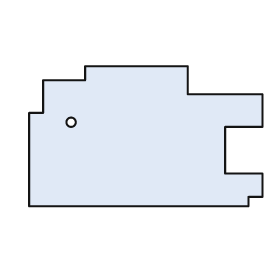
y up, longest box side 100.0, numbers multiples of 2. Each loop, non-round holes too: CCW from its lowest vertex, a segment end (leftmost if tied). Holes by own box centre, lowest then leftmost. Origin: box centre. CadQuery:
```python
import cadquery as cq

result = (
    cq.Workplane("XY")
    .moveTo(-50.0, -30.0)
    .lineTo(44.0, -30.0)
    .lineTo(44.0, -26.0)
    .lineTo(50.0, -26.0)
    .lineTo(50.0, -16.0)
    .lineTo(34.0, -16.0)
    .lineTo(34.0, 4.0)
    .lineTo(50.0, 4.0)
    .lineTo(50.0, 18.0)
    .lineTo(18.0, 18.0)
    .lineTo(18.0, 30.0)
    .lineTo(-26.0, 30.0)
    .lineTo(-26.0, 24.0)
    .lineTo(-44.0, 24.0)
    .lineTo(-44.0, 10.0)
    .lineTo(-50.0, 10.0)
    .close()
    .moveTo(-32.0, 6.0)
    .circle(2.0)
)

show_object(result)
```